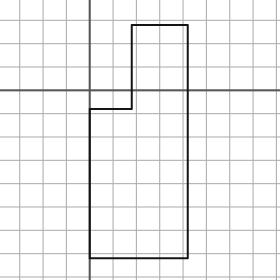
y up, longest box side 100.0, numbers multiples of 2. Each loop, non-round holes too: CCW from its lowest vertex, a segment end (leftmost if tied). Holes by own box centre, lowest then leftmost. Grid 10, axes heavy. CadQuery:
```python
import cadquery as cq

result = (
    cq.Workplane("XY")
    .moveTo(0.0, -72.0)
    .lineTo(42.0, -72.0)
    .lineTo(42.0, 28.0)
    .lineTo(18.0, 28.0)
    .lineTo(18.0, -8.0)
    .lineTo(0.0, -8.0)
    .close()
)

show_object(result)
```